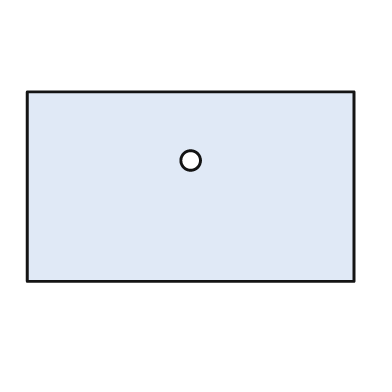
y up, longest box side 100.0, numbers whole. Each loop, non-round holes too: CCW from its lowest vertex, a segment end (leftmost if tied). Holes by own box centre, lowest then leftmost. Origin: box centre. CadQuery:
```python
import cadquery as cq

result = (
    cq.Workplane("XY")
    .moveTo(-50.0, -29.0)
    .lineTo(50.0, -29.0)
    .lineTo(50.0, 29.0)
    .lineTo(-50.0, 29.0)
    .close()
    .moveTo(0.0, 8.0)
    .circle(3.0)
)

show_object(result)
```